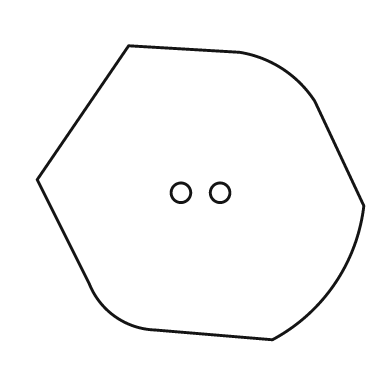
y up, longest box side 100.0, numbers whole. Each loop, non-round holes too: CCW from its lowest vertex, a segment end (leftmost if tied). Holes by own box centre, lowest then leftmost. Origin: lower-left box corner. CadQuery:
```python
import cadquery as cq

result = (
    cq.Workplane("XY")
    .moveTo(72.0, 0.0)
    .threePointArc((91.0, 17.0), (100.0, 41.0))
    .lineTo(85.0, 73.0)
    .threePointArc((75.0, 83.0), (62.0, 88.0))
    .lineTo(28.0, 90.0)
    .lineTo(0.0, 49.0)
    .lineTo(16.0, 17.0)
    .threePointArc((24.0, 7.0), (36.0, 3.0))
    .close()
    .moveTo(44.0, 45.0)
    .circle(3.0)
    .moveTo(56.0, 45.0)
    .circle(3.0)
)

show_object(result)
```